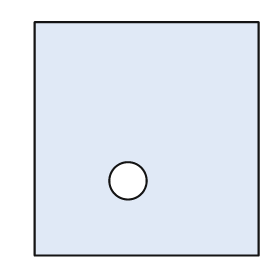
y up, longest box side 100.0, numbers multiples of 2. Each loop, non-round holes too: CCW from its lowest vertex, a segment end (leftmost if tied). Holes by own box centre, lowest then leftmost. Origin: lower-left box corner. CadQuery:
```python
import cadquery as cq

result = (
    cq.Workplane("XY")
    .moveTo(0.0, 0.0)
    .lineTo(96.0, 0.0)
    .lineTo(96.0, 100.0)
    .lineTo(0.0, 100.0)
    .close()
    .moveTo(40.0, 32.0)
    .circle(8.0)
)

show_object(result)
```